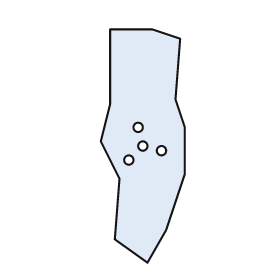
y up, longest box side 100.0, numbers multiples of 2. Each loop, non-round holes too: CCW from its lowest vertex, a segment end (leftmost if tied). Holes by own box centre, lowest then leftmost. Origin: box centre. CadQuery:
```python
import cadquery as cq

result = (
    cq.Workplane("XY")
    .moveTo(2.0, -50.0)
    .lineTo(10.0, -36.0)
    .lineTo(18.0, -12.0)
    .lineTo(18.0, 8.0)
    .lineTo(14.0, 20.0)
    .lineTo(16.0, 46.0)
    .lineTo(4.0, 50.0)
    .lineTo(-14.0, 50.0)
    .lineTo(-14.0, 18.0)
    .lineTo(-18.0, 2.0)
    .lineTo(-10.0, -14.0)
    .lineTo(-12.0, -40.0)
    .close()
    .moveTo(-6.0, -6.0)
    .circle(2.0)
    .moveTo(8.0, -2.0)
    .circle(2.0)
    .moveTo(0.0, 0.0)
    .circle(2.0)
    .moveTo(-2.0, 8.0)
    .circle(2.0)
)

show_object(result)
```